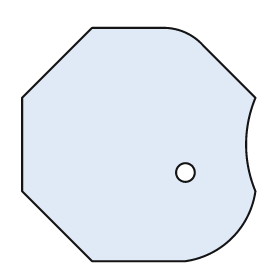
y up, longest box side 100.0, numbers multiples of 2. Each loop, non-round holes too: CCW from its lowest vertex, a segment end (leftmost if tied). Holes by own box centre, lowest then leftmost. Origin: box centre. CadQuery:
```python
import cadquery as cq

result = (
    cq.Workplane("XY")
    .moveTo(-20.0, -50.0)
    .lineTo(20.0, -50.0)
    .threePointArc((40.0, -40.0), (50.0, -20.0))
    .threePointArc((46.0, 0.0), (50.0, 20.0))
    .lineTo(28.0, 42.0)
    .threePointArc((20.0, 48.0), (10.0, 50.0))
    .lineTo(-20.0, 50.0)
    .lineTo(-50.0, 20.0)
    .lineTo(-50.0, -20.0)
    .close()
    .moveTo(20.0, -12.0)
    .circle(4.0)
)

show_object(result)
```